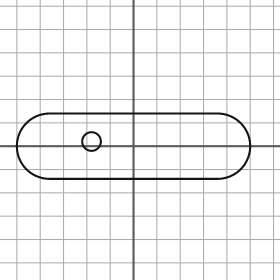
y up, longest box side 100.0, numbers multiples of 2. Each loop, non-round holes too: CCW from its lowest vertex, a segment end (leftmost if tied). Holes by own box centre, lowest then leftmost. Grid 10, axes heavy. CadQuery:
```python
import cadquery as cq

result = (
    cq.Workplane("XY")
    .moveTo(-36.0, -14.0)
    .lineTo(36.0, -14.0)
    .threePointArc((50.0, 0.0), (36.0, 14.0))
    .lineTo(-36.0, 14.0)
    .threePointArc((-50.0, 0.0), (-36.0, -14.0))
    .close()
    .moveTo(-18.0, 2.0)
    .circle(4.0)
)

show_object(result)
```